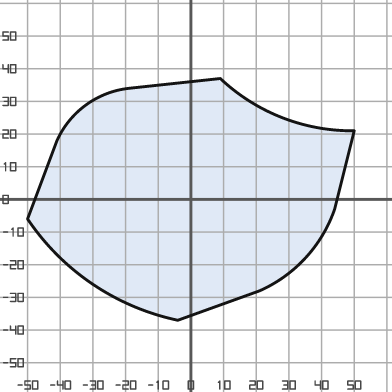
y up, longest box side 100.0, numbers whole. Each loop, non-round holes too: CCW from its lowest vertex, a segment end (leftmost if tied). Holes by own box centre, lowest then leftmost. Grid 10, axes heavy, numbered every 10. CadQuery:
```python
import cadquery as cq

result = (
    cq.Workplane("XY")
    .moveTo(-4.0, -37.0)
    .lineTo(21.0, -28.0)
    .threePointArc((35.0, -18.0), (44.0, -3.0))
    .lineTo(50.0, 21.0)
    .threePointArc((28.0, 25.0), (9.0, 37.0))
    .lineTo(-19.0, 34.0)
    .threePointArc((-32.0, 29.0), (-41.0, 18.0))
    .lineTo(-50.0, -6.0)
    .threePointArc((-30.0, -26.0), (-4.0, -37.0))
    .close()
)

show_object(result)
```